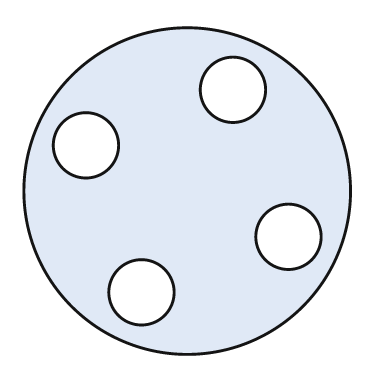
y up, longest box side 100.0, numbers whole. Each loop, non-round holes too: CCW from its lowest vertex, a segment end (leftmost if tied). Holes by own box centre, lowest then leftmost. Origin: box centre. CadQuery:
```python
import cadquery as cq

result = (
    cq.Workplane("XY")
    .moveTo(0.0, 0.0)
    .circle(50.0)
    .moveTo(-14.0, -31.0)
    .circle(10.0)
    .moveTo(31.0, -14.0)
    .circle(10.0)
    .moveTo(-31.0, 14.0)
    .circle(10.0)
    .moveTo(14.0, 31.0)
    .circle(10.0)
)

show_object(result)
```